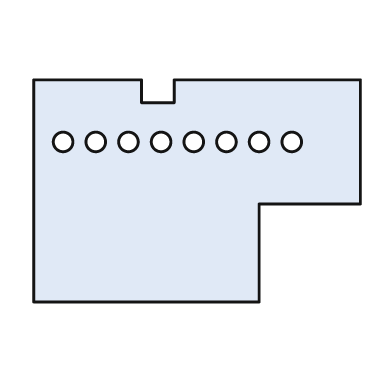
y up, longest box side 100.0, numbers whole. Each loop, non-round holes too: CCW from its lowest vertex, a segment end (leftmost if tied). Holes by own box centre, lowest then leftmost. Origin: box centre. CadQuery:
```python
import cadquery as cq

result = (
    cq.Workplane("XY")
    .moveTo(-50.0, -34.0)
    .lineTo(19.0, -34.0)
    .lineTo(19.0, -4.0)
    .lineTo(50.0, -4.0)
    .lineTo(50.0, 34.0)
    .lineTo(-7.0, 34.0)
    .lineTo(-7.0, 27.0)
    .lineTo(-17.0, 27.0)
    .lineTo(-17.0, 34.0)
    .lineTo(-50.0, 34.0)
    .close()
    .moveTo(-41.0, 15.0)
    .circle(3.0)
    .moveTo(-31.0, 15.0)
    .circle(3.0)
    .moveTo(-21.0, 15.0)
    .circle(3.0)
    .moveTo(-11.0, 15.0)
    .circle(3.0)
    .moveTo(-1.0, 15.0)
    .circle(3.0)
    .moveTo(9.0, 15.0)
    .circle(3.0)
    .moveTo(19.0, 15.0)
    .circle(3.0)
    .moveTo(29.0, 15.0)
    .circle(3.0)
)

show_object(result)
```